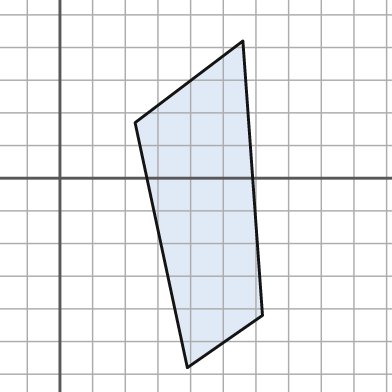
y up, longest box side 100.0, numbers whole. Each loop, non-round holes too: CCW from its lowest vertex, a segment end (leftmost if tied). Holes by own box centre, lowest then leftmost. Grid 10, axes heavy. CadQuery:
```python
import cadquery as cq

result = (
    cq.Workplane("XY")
    .moveTo(39.0, -58.0)
    .lineTo(62.0, -42.0)
    .lineTo(56.0, 42.0)
    .lineTo(23.0, 17.0)
    .close()
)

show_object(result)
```